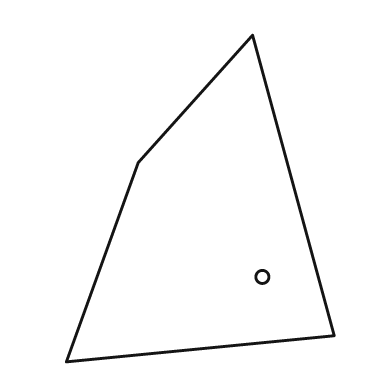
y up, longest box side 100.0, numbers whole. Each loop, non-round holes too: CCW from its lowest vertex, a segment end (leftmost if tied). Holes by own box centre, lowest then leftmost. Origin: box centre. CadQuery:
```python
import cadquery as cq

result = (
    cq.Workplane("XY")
    .moveTo(-41.0, -50.0)
    .lineTo(41.0, -42.0)
    .lineTo(16.0, 50.0)
    .lineTo(-19.0, 11.0)
    .close()
    .moveTo(19.0, -24.0)
    .circle(2.0)
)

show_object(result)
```